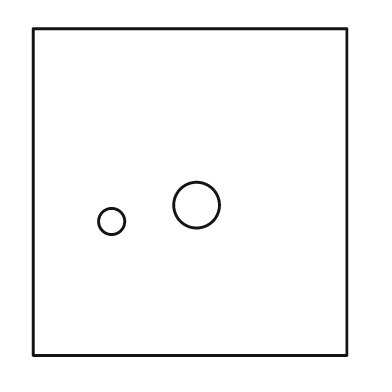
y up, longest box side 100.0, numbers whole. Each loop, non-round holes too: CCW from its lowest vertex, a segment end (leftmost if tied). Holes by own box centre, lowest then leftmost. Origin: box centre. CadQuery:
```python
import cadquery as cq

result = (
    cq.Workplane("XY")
    .moveTo(-48.0, -50.0)
    .lineTo(48.0, -50.0)
    .lineTo(48.0, 50.0)
    .lineTo(-48.0, 50.0)
    .close()
    .moveTo(-24.0, -9.0)
    .circle(4.0)
    .moveTo(2.0, -4.0)
    .circle(7.0)
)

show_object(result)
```